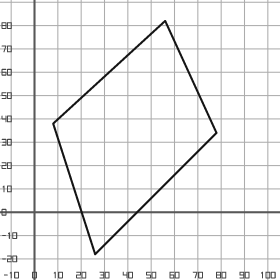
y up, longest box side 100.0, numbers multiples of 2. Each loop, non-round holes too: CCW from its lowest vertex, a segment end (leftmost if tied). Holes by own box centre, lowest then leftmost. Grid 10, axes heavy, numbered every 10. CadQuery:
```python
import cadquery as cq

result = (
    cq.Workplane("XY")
    .moveTo(26.0, -18.0)
    .lineTo(78.0, 34.0)
    .lineTo(56.0, 82.0)
    .lineTo(8.0, 38.0)
    .close()
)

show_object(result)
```